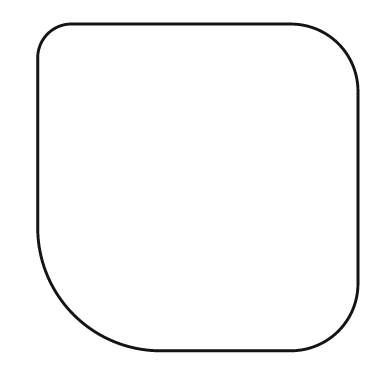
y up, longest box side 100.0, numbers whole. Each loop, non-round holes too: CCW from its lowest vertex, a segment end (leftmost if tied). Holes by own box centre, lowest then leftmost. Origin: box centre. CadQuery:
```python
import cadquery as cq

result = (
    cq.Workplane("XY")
    .moveTo(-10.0, -50.0)
    .lineTo(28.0, -50.0)
    .threePointArc((43.0, -44.0), (49.0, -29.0))
    .lineTo(49.0, 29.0)
    .threePointArc((43.0, 44.0), (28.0, 50.0))
    .lineTo(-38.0, 50.0)
    .threePointArc((-46.0, 47.0), (-49.0, 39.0))
    .lineTo(-49.0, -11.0)
    .threePointArc((-38.0, -39.0), (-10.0, -50.0))
    .close()
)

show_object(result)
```